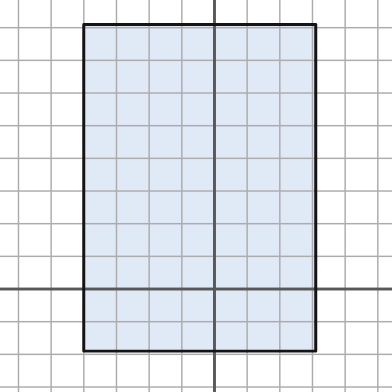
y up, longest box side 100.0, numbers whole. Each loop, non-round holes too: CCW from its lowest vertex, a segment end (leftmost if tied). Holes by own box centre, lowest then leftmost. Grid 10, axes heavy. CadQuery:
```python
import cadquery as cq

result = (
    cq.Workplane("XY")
    .moveTo(-40.0, -19.0)
    .lineTo(31.0, -19.0)
    .lineTo(31.0, 81.0)
    .lineTo(-40.0, 81.0)
    .close()
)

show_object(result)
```